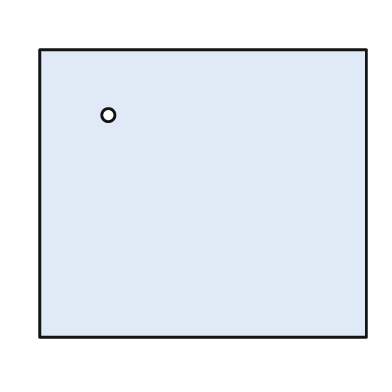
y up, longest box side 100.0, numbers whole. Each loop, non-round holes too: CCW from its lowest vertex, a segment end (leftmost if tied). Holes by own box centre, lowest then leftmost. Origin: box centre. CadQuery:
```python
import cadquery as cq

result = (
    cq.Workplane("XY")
    .moveTo(-50.0, -44.0)
    .lineTo(50.0, -44.0)
    .lineTo(50.0, 44.0)
    .lineTo(-50.0, 44.0)
    .close()
    .moveTo(-29.0, 24.0)
    .circle(2.0)
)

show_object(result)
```